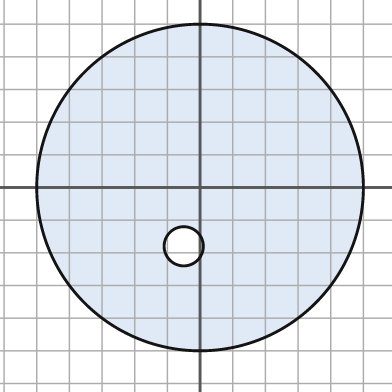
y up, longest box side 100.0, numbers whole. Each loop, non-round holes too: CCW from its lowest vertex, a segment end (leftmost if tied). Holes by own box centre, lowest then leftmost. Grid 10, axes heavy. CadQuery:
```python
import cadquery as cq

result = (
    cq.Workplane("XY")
    .moveTo(0.0, 0.0)
    .circle(50.0)
    .moveTo(-5.0, -18.0)
    .circle(6.0)
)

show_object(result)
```